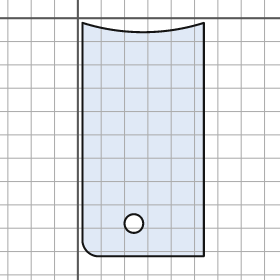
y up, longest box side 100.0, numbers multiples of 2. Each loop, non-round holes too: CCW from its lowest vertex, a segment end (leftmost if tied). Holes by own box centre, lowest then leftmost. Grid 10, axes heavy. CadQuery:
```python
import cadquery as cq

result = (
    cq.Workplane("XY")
    .moveTo(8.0, -102.0)
    .lineTo(54.0, -102.0)
    .lineTo(54.0, -2.0)
    .threePointArc((28.0, -6.0), (2.0, -2.0))
    .lineTo(2.0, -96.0)
    .threePointArc((4.0, -100.0), (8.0, -102.0))
    .close()
    .moveTo(24.0, -88.0)
    .circle(4.0)
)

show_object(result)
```